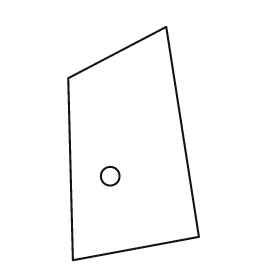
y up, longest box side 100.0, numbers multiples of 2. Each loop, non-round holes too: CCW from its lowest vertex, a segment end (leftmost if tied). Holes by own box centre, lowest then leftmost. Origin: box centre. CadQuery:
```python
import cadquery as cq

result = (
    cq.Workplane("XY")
    .moveTo(-26.0, -50.0)
    .lineTo(28.0, -40.0)
    .lineTo(14.0, 50.0)
    .lineTo(-28.0, 28.0)
    .close()
    .moveTo(-10.0, -14.0)
    .circle(4.0)
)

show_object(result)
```